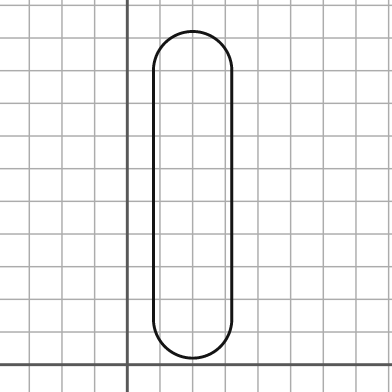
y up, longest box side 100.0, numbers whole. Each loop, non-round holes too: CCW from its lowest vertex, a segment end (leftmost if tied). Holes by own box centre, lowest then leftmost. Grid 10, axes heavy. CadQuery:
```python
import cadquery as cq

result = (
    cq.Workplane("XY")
    .moveTo(8.0, 14.0)
    .threePointArc((20.0, 2.0), (32.0, 14.0))
    .lineTo(32.0, 90.0)
    .threePointArc((20.0, 102.0), (8.0, 90.0))
    .close()
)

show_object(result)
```